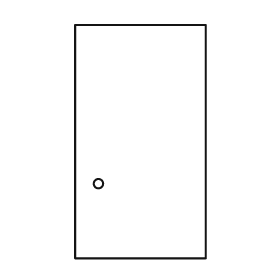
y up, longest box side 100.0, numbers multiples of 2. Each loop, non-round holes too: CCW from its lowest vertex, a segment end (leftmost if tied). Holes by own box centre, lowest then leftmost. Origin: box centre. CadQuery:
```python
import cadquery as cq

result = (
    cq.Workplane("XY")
    .moveTo(-28.0, -50.0)
    .lineTo(28.0, -50.0)
    .lineTo(28.0, 50.0)
    .lineTo(-28.0, 50.0)
    .close()
    .moveTo(-18.0, -18.0)
    .circle(2.0)
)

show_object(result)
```